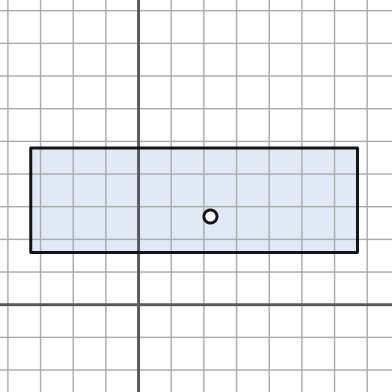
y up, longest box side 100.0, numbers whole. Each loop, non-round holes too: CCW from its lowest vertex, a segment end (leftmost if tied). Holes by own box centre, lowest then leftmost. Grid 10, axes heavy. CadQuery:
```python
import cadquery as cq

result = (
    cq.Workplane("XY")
    .moveTo(-33.0, 16.0)
    .lineTo(67.0, 16.0)
    .lineTo(67.0, 48.0)
    .lineTo(-33.0, 48.0)
    .close()
    .moveTo(22.0, 27.0)
    .circle(2.0)
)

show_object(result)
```